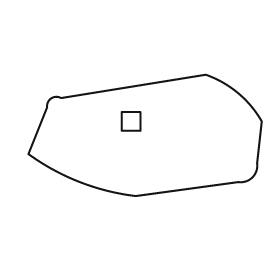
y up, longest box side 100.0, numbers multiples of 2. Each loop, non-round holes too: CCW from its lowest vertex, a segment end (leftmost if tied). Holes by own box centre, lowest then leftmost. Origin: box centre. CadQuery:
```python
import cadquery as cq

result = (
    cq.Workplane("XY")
    .moveTo(-4.0, -26.0)
    .lineTo(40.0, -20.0)
    .threePointArc((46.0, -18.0), (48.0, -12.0))
    .lineTo(50.0, 6.0)
    .threePointArc((40.0, 18.0), (26.0, 26.0))
    .lineTo(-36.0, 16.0)
    .threePointArc((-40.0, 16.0), (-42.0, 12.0))
    .lineTo(-50.0, -8.0)
    .threePointArc((-28.0, -20.0), (-4.0, -26.0))
    .close()
    .moveTo(-10.0, 2.0)
    .lineTo(-2.0, 2.0)
    .lineTo(-2.0, 10.0)
    .lineTo(-10.0, 10.0)
    .close()
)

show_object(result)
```